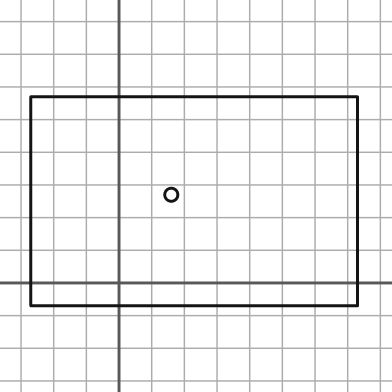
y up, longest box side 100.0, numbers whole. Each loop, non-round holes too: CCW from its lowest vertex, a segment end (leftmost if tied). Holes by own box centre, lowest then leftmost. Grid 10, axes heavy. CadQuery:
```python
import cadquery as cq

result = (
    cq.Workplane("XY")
    .moveTo(-27.0, -7.0)
    .lineTo(73.0, -7.0)
    .lineTo(73.0, 57.0)
    .lineTo(-27.0, 57.0)
    .close()
    .moveTo(16.0, 27.0)
    .circle(2.0)
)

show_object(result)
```